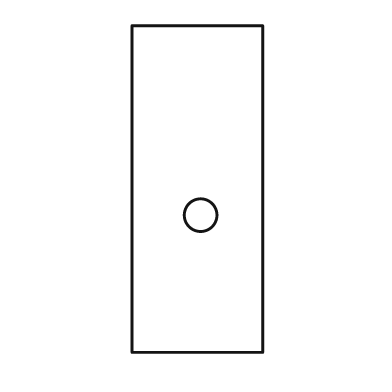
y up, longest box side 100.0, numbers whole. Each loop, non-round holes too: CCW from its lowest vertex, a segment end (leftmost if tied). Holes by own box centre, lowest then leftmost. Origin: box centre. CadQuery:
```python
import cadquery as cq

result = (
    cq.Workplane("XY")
    .moveTo(-20.0, -50.0)
    .lineTo(20.0, -50.0)
    .lineTo(20.0, 50.0)
    .lineTo(-20.0, 50.0)
    .close()
    .moveTo(1.0, -8.0)
    .circle(5.0)
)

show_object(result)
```